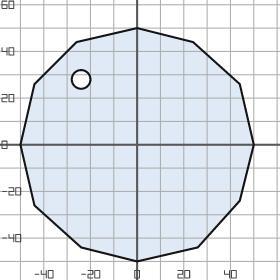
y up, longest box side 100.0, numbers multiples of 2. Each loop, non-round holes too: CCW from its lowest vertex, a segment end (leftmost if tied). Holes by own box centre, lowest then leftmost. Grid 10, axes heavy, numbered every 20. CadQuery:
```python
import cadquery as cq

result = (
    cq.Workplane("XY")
    .moveTo(0.0, -50.0)
    .lineTo(26.0, -44.0)
    .lineTo(44.0, -24.0)
    .lineTo(50.0, 0.0)
    .lineTo(44.0, 26.0)
    .lineTo(24.0, 44.0)
    .lineTo(0.0, 50.0)
    .lineTo(-26.0, 44.0)
    .lineTo(-44.0, 26.0)
    .lineTo(-50.0, 0.0)
    .lineTo(-44.0, -26.0)
    .lineTo(-24.0, -44.0)
    .close()
    .moveTo(-24.0, 28.0)
    .circle(4.0)
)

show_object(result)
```